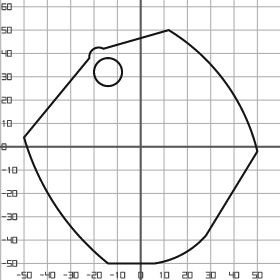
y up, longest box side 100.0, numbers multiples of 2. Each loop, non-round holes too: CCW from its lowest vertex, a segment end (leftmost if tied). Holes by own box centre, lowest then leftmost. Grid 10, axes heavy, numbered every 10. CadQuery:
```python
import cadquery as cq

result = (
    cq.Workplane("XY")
    .moveTo(-14.0, -50.0)
    .lineTo(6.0, -50.0)
    .threePointArc((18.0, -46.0), (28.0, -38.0))
    .lineTo(50.0, -2.0)
    .threePointArc((36.0, 28.0), (12.0, 50.0))
    .lineTo(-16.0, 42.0)
    .threePointArc((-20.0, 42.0), (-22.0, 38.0))
    .lineTo(-50.0, 4.0)
    .threePointArc((-36.0, -26.0), (-14.0, -50.0))
    .close()
    .moveTo(-14.0, 32.0)
    .circle(6.0)
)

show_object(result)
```